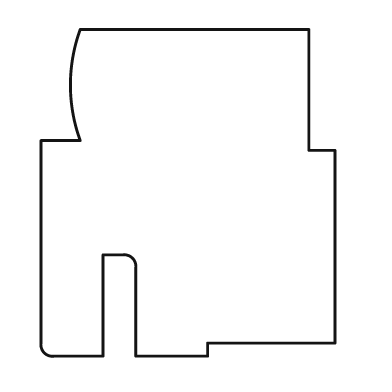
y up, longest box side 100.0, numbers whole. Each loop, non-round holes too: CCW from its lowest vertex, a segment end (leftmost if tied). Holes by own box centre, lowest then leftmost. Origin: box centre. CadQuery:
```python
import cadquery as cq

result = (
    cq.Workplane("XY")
    .moveTo(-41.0, -50.0)
    .lineTo(-26.0, -50.0)
    .lineTo(-26.0, -19.0)
    .lineTo(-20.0, -19.0)
    .threePointArc((-17.0, -20.0), (-16.0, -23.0))
    .lineTo(-16.0, -50.0)
    .lineTo(6.0, -50.0)
    .lineTo(6.0, -46.0)
    .lineTo(45.0, -46.0)
    .lineTo(45.0, 13.0)
    .lineTo(37.0, 13.0)
    .lineTo(37.0, 50.0)
    .lineTo(-33.0, 50.0)
    .threePointArc((-36.0, 33.0), (-33.0, 16.0))
    .lineTo(-45.0, 16.0)
    .lineTo(-45.0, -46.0)
    .threePointArc((-44.0, -49.0), (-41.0, -50.0))
    .close()
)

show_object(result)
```